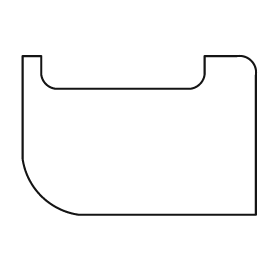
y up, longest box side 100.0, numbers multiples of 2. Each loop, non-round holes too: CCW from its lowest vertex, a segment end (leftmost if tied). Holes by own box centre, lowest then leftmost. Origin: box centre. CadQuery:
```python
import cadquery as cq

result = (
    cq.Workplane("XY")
    .moveTo(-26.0, -34.0)
    .lineTo(50.0, -34.0)
    .lineTo(50.0, 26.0)
    .threePointArc((48.0, 32.0), (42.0, 34.0))
    .lineTo(28.0, 34.0)
    .lineTo(28.0, 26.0)
    .threePointArc((26.0, 22.0), (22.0, 20.0))
    .lineTo(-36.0, 20.0)
    .threePointArc((-40.0, 22.0), (-42.0, 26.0))
    .lineTo(-42.0, 34.0)
    .lineTo(-50.0, 34.0)
    .lineTo(-50.0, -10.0)
    .threePointArc((-42.0, -26.0), (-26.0, -34.0))
    .close()
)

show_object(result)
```